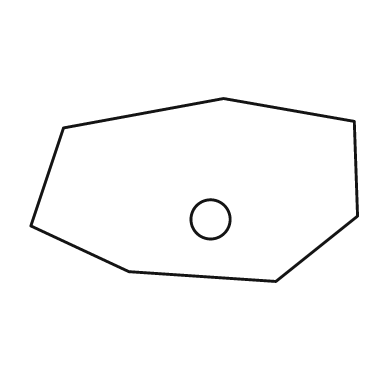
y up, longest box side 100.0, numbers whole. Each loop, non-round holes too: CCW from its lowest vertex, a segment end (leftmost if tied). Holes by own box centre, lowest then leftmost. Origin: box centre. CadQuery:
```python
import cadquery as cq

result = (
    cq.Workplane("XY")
    .moveTo(25.0, -28.0)
    .lineTo(50.0, -8.0)
    .lineTo(49.0, 21.0)
    .lineTo(9.0, 28.0)
    .lineTo(-40.0, 19.0)
    .lineTo(-50.0, -11.0)
    .lineTo(-20.0, -25.0)
    .close()
    .moveTo(5.0, -9.0)
    .circle(6.0)
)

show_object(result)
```